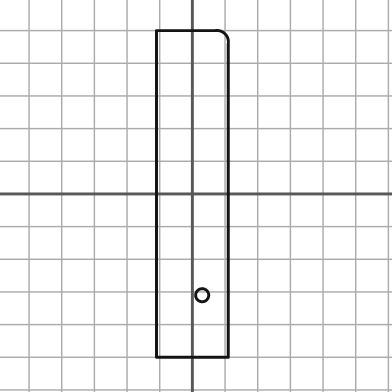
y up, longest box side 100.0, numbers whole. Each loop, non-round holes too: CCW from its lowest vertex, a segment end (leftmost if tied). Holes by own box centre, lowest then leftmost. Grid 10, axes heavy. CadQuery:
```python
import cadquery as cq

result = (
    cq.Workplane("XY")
    .moveTo(-11.0, -50.0)
    .lineTo(11.0, -50.0)
    .lineTo(11.0, 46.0)
    .threePointArc((10.0, 49.0), (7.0, 50.0))
    .lineTo(-11.0, 50.0)
    .close()
    .moveTo(3.0, -31.0)
    .circle(2.0)
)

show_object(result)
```